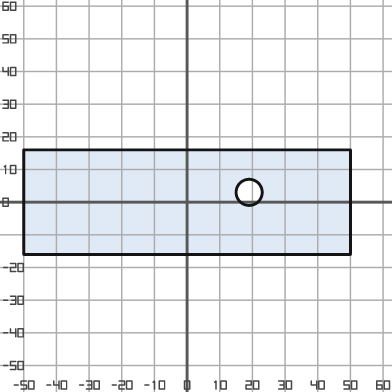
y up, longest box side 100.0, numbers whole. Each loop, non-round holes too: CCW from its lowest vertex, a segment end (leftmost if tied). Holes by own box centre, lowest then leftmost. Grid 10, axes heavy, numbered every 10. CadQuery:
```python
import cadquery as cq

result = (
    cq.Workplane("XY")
    .moveTo(-50.0, -16.0)
    .lineTo(50.0, -16.0)
    .lineTo(50.0, 16.0)
    .lineTo(-50.0, 16.0)
    .close()
    .moveTo(19.0, 3.0)
    .circle(4.0)
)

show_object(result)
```